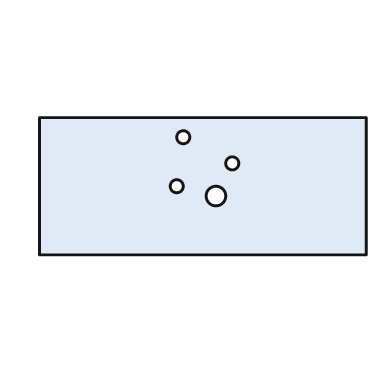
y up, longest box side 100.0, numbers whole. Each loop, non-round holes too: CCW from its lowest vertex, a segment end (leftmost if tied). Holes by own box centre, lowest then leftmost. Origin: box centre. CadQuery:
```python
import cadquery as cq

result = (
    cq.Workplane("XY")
    .moveTo(-50.0, -21.0)
    .lineTo(50.0, -21.0)
    .lineTo(50.0, 21.0)
    .lineTo(-50.0, 21.0)
    .close()
    .moveTo(4.0, -3.0)
    .circle(3.0)
    .moveTo(-8.0, 0.0)
    .circle(2.0)
    .moveTo(9.0, 7.0)
    .circle(2.0)
    .moveTo(-6.0, 15.0)
    .circle(2.0)
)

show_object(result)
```